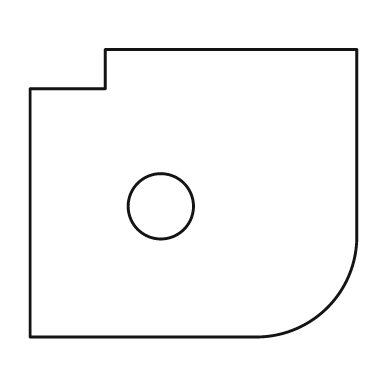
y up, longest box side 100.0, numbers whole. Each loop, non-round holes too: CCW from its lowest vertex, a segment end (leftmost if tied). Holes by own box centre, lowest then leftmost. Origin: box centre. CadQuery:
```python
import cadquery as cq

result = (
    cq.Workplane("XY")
    .moveTo(-50.0, -44.0)
    .lineTo(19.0, -44.0)
    .threePointArc((41.0, -35.0), (50.0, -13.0))
    .lineTo(50.0, 44.0)
    .lineTo(-27.0, 44.0)
    .lineTo(-27.0, 32.0)
    .lineTo(-50.0, 32.0)
    .close()
    .moveTo(-10.0, -4.0)
    .circle(10.0)
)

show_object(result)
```